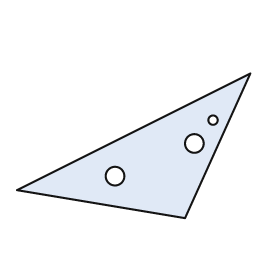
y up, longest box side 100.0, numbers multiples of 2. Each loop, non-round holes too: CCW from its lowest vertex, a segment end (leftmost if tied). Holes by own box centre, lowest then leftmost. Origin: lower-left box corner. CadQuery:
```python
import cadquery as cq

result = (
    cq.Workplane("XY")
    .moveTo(72.0, 0.0)
    .lineTo(100.0, 62.0)
    .lineTo(0.0, 12.0)
    .close()
    .moveTo(42.0, 18.0)
    .circle(4.0)
    .moveTo(76.0, 32.0)
    .circle(4.0)
    .moveTo(84.0, 42.0)
    .circle(2.0)
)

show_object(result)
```